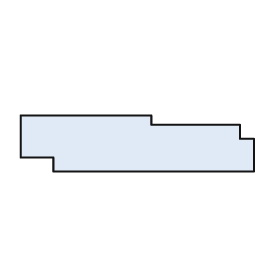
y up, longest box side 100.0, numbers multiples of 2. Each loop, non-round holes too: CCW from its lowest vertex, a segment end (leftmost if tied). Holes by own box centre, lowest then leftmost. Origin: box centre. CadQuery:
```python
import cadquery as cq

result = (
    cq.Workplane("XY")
    .moveTo(-36.0, -12.0)
    .lineTo(50.0, -12.0)
    .lineTo(50.0, 2.0)
    .lineTo(44.0, 2.0)
    .lineTo(44.0, 8.0)
    .lineTo(6.0, 8.0)
    .lineTo(6.0, 12.0)
    .lineTo(-50.0, 12.0)
    .lineTo(-50.0, -6.0)
    .lineTo(-36.0, -6.0)
    .close()
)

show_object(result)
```